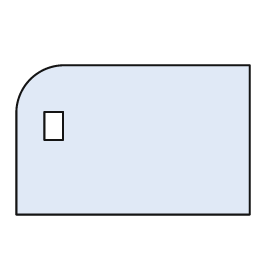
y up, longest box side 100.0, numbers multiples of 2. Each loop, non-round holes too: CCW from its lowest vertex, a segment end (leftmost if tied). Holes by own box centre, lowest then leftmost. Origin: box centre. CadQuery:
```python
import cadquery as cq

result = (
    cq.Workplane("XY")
    .moveTo(-50.0, -32.0)
    .lineTo(50.0, -32.0)
    .lineTo(50.0, 32.0)
    .lineTo(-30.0, 32.0)
    .threePointArc((-44.0, 26.0), (-50.0, 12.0))
    .close()
    .moveTo(-38.0, 0.0)
    .lineTo(-30.0, 0.0)
    .lineTo(-30.0, 12.0)
    .lineTo(-38.0, 12.0)
    .close()
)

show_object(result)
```